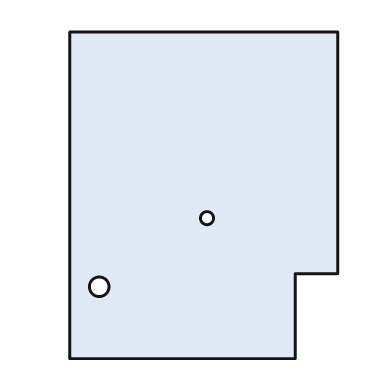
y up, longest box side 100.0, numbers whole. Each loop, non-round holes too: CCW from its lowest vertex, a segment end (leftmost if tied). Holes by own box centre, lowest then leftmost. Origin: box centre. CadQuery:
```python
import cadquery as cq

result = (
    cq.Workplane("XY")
    .moveTo(-41.0, -50.0)
    .lineTo(28.0, -50.0)
    .lineTo(28.0, -24.0)
    .lineTo(41.0, -24.0)
    .lineTo(41.0, 50.0)
    .lineTo(-41.0, 50.0)
    .close()
    .moveTo(-32.0, -28.0)
    .circle(3.0)
    .moveTo(1.0, -7.0)
    .circle(2.0)
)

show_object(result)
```